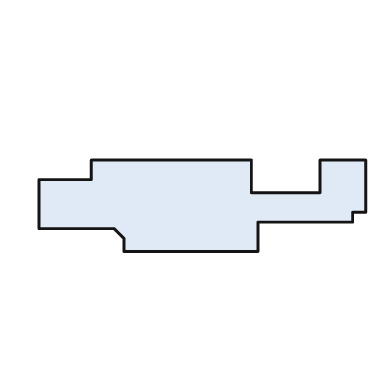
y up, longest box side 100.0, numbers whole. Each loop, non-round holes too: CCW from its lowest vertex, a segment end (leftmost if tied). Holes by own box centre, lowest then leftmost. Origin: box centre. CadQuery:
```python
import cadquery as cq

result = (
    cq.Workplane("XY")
    .moveTo(-24.0, -14.0)
    .lineTo(17.0, -14.0)
    .lineTo(17.0, -5.0)
    .lineTo(46.0, -5.0)
    .lineTo(46.0, -2.0)
    .lineTo(50.0, -2.0)
    .lineTo(50.0, 14.0)
    .lineTo(36.0, 14.0)
    .lineTo(36.0, 4.0)
    .lineTo(15.0, 4.0)
    .lineTo(15.0, 14.0)
    .lineTo(-34.0, 14.0)
    .lineTo(-34.0, 8.0)
    .lineTo(-50.0, 8.0)
    .lineTo(-50.0, -7.0)
    .lineTo(-27.0, -7.0)
    .lineTo(-24.0, -10.0)
    .close()
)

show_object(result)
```